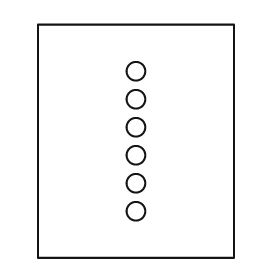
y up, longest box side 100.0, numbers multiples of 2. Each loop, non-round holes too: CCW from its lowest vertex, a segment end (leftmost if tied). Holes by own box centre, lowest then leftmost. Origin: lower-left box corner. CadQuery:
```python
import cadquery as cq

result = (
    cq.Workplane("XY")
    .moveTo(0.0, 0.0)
    .lineTo(84.0, 0.0)
    .lineTo(84.0, 100.0)
    .lineTo(0.0, 100.0)
    .close()
    .moveTo(42.0, 20.0)
    .circle(4.0)
    .moveTo(42.0, 32.0)
    .circle(4.0)
    .moveTo(42.0, 44.0)
    .circle(4.0)
    .moveTo(42.0, 56.0)
    .circle(4.0)
    .moveTo(42.0, 68.0)
    .circle(4.0)
    .moveTo(42.0, 80.0)
    .circle(4.0)
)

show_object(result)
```